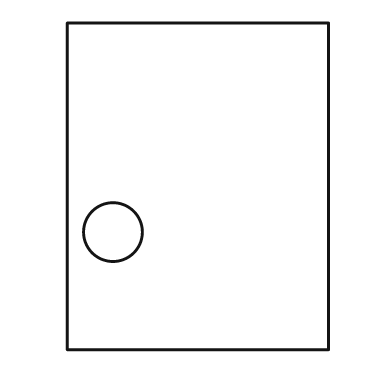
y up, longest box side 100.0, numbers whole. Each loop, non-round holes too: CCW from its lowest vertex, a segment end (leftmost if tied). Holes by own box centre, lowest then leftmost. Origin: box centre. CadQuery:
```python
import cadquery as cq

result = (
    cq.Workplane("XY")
    .moveTo(-40.0, -50.0)
    .lineTo(40.0, -50.0)
    .lineTo(40.0, 50.0)
    .lineTo(-40.0, 50.0)
    .close()
    .moveTo(-26.0, -14.0)
    .circle(9.0)
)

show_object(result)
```